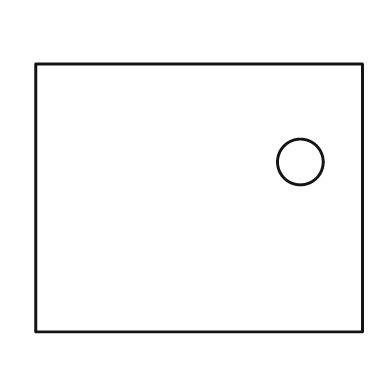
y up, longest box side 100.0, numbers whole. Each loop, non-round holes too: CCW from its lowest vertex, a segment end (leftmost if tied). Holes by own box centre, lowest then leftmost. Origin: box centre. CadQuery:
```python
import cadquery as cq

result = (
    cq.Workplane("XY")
    .moveTo(-50.0, -41.0)
    .lineTo(50.0, -41.0)
    .lineTo(50.0, 41.0)
    .lineTo(-50.0, 41.0)
    .close()
    .moveTo(31.0, 11.0)
    .circle(7.0)
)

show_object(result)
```